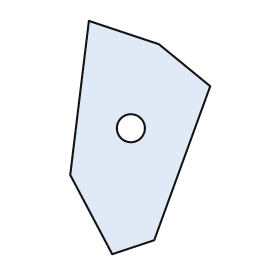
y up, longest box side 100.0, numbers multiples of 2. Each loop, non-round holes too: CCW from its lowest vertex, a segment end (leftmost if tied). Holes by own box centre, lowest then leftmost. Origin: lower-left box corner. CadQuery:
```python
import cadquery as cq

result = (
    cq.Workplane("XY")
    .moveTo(18.0, 0.0)
    .lineTo(36.0, 6.0)
    .lineTo(60.0, 72.0)
    .lineTo(38.0, 90.0)
    .lineTo(8.0, 100.0)
    .lineTo(0.0, 34.0)
    .close()
    .moveTo(26.0, 54.0)
    .circle(6.0)
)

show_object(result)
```